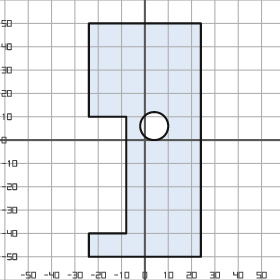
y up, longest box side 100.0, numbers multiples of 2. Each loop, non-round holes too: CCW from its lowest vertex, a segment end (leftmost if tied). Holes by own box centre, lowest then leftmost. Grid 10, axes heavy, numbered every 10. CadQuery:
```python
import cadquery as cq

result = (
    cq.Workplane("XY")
    .moveTo(-24.0, -50.0)
    .lineTo(24.0, -50.0)
    .lineTo(24.0, 50.0)
    .lineTo(-24.0, 50.0)
    .lineTo(-24.0, 10.0)
    .lineTo(-8.0, 10.0)
    .lineTo(-8.0, -40.0)
    .lineTo(-24.0, -40.0)
    .close()
    .moveTo(4.0, 6.0)
    .circle(6.0)
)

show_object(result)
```